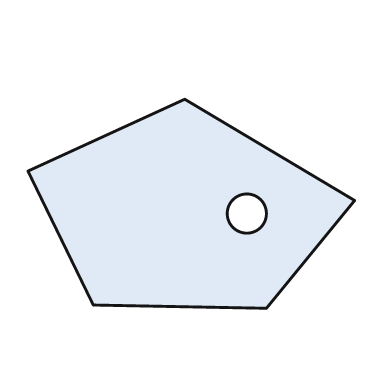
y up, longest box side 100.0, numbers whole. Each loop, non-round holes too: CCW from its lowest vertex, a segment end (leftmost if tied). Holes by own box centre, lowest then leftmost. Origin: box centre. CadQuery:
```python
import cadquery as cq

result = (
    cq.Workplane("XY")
    .moveTo(23.0, -32.0)
    .lineTo(50.0, 1.0)
    .lineTo(-2.0, 32.0)
    .lineTo(-50.0, 10.0)
    .lineTo(-30.0, -31.0)
    .close()
    .moveTo(17.0, -3.0)
    .circle(6.0)
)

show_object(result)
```